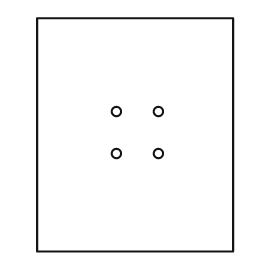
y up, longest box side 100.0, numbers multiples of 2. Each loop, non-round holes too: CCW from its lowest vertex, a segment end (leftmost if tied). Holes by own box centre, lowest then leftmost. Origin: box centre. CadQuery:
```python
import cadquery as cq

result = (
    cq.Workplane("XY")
    .moveTo(-42.0, -50.0)
    .lineTo(42.0, -50.0)
    .lineTo(42.0, 50.0)
    .lineTo(-42.0, 50.0)
    .close()
    .moveTo(-8.0, -8.0)
    .circle(2.0)
    .moveTo(10.0, -8.0)
    .circle(2.0)
    .moveTo(-8.0, 10.0)
    .circle(2.0)
    .moveTo(10.0, 10.0)
    .circle(2.0)
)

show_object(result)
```